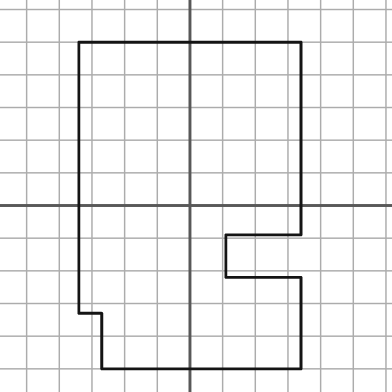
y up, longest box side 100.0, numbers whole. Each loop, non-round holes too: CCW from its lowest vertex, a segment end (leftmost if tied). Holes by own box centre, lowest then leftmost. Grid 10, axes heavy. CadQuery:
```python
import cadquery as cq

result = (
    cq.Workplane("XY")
    .moveTo(-27.0, -50.0)
    .lineTo(34.0, -50.0)
    .lineTo(34.0, -22.0)
    .lineTo(11.0, -22.0)
    .lineTo(11.0, -9.0)
    .lineTo(34.0, -9.0)
    .lineTo(34.0, 50.0)
    .lineTo(-34.0, 50.0)
    .lineTo(-34.0, -33.0)
    .lineTo(-27.0, -33.0)
    .close()
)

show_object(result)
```